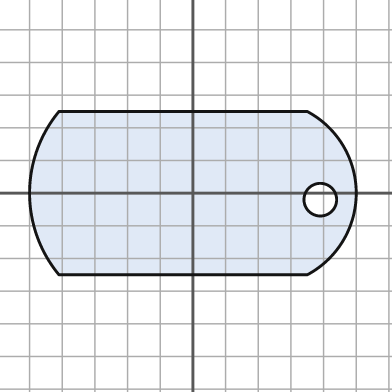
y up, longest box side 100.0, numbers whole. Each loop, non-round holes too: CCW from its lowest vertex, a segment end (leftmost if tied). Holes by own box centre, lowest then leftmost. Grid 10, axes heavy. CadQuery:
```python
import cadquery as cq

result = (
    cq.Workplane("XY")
    .moveTo(-41.0, -25.0)
    .lineTo(35.0, -25.0)
    .threePointArc((50.0, 0.0), (35.0, 25.0))
    .lineTo(-41.0, 25.0)
    .threePointArc((-50.0, 0.0), (-41.0, -25.0))
    .close()
    .moveTo(39.0, -2.0)
    .circle(5.0)
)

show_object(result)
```